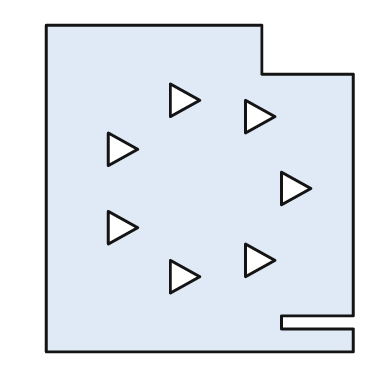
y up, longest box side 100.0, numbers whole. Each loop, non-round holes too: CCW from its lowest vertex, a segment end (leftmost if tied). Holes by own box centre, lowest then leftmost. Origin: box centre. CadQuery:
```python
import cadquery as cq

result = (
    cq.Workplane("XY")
    .moveTo(-47.0, -50.0)
    .lineTo(47.0, -50.0)
    .lineTo(47.0, -43.0)
    .lineTo(25.0, -43.0)
    .lineTo(25.0, -39.0)
    .lineTo(47.0, -39.0)
    .lineTo(47.0, 35.0)
    .lineTo(19.0, 35.0)
    .lineTo(19.0, 50.0)
    .lineTo(-47.0, 50.0)
    .close()
    .moveTo(-9.0, -32.0)
    .lineTo(0.0, -27.0)
    .lineTo(-9.0, -22.0)
    .close()
    .moveTo(14.0, -27.0)
    .lineTo(23.0, -22.0)
    .lineTo(14.0, -17.0)
    .close()
    .moveTo(-28.0, -17.0)
    .lineTo(-19.0, -12.0)
    .lineTo(-28.0, -7.0)
    .close()
    .moveTo(25.0, -5.0)
    .lineTo(34.0, 0.0)
    .lineTo(25.0, 5.0)
    .close()
    .moveTo(-28.0, 7.0)
    .lineTo(-19.0, 12.0)
    .lineTo(-28.0, 17.0)
    .close()
    .moveTo(14.0, 17.0)
    .lineTo(23.0, 22.0)
    .lineTo(14.0, 27.0)
    .close()
    .moveTo(-9.0, 22.0)
    .lineTo(0.0, 27.0)
    .lineTo(-9.0, 32.0)
    .close()
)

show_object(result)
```